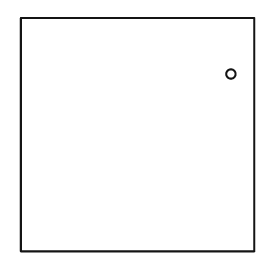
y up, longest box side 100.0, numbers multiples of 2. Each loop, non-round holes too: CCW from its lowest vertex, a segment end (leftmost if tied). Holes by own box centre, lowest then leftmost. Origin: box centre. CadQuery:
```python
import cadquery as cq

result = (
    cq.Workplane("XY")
    .moveTo(-50.0, -50.0)
    .lineTo(50.0, -50.0)
    .lineTo(50.0, 50.0)
    .lineTo(-50.0, 50.0)
    .close()
    .moveTo(40.0, 26.0)
    .circle(2.0)
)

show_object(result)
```